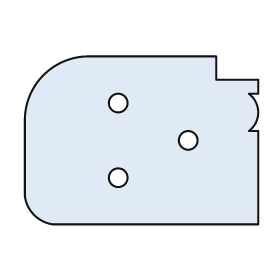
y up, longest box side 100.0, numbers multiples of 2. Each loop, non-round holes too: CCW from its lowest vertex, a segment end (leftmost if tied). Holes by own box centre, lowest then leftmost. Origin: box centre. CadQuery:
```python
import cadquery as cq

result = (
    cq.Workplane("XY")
    .moveTo(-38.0, -36.0)
    .lineTo(50.0, -36.0)
    .lineTo(50.0, 4.0)
    .lineTo(46.0, 4.0)
    .threePointArc((50.0, 12.0), (46.0, 20.0))
    .lineTo(50.0, 20.0)
    .lineTo(50.0, 26.0)
    .lineTo(32.0, 26.0)
    .lineTo(32.0, 36.0)
    .lineTo(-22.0, 36.0)
    .threePointArc((-42.0, 28.0), (-50.0, 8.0))
    .lineTo(-50.0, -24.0)
    .threePointArc((-46.0, -32.0), (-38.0, -36.0))
    .close()
    .moveTo(-10.0, -16.0)
    .circle(4.0)
    .moveTo(20.0, 0.0)
    .circle(4.0)
    .moveTo(-10.0, 16.0)
    .circle(4.0)
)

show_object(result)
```